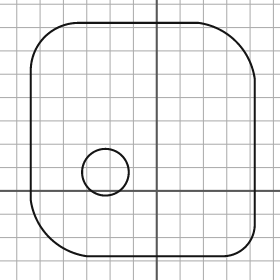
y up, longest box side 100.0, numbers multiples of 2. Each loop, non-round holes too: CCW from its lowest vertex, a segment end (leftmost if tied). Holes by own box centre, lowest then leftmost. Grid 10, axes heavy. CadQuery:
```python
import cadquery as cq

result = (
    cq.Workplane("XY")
    .moveTo(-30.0, -28.0)
    .lineTo(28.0, -28.0)
    .threePointArc((38.0, -24.0), (42.0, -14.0))
    .lineTo(42.0, 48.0)
    .threePointArc((34.0, 64.0), (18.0, 72.0))
    .lineTo(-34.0, 72.0)
    .threePointArc((-48.0, 66.0), (-54.0, 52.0))
    .lineTo(-54.0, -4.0)
    .threePointArc((-46.0, -20.0), (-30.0, -28.0))
    .close()
    .moveTo(-22.0, 8.0)
    .circle(10.0)
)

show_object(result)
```